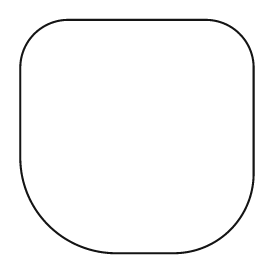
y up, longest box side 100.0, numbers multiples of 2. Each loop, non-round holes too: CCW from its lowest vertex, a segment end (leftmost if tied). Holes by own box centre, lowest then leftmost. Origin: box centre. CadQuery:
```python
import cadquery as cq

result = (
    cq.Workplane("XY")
    .moveTo(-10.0, -50.0)
    .lineTo(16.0, -50.0)
    .threePointArc((40.0, -40.0), (50.0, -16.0))
    .lineTo(50.0, 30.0)
    .threePointArc((44.0, 44.0), (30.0, 50.0))
    .lineTo(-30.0, 50.0)
    .threePointArc((-44.0, 44.0), (-50.0, 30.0))
    .lineTo(-50.0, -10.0)
    .threePointArc((-38.0, -38.0), (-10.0, -50.0))
    .close()
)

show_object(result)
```